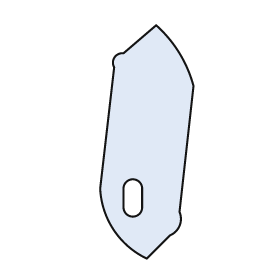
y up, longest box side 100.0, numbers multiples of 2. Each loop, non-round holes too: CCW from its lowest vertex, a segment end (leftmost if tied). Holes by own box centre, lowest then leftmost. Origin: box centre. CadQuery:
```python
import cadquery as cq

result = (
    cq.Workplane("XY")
    .moveTo(0.0, -50.0)
    .lineTo(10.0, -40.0)
    .threePointArc((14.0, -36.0), (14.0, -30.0))
    .lineTo(20.0, 24.0)
    .threePointArc((14.0, 38.0), (4.0, 50.0))
    .lineTo(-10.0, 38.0)
    .threePointArc((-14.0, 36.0), (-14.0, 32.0))
    .lineTo(-20.0, -20.0)
    .threePointArc((-14.0, -38.0), (0.0, -50.0))
    .close()
    .moveTo(-10.0, -28.0)
    .threePointArc((-6.0, -32.0), (-2.0, -28.0))
    .lineTo(-2.0, -20.0)
    .threePointArc((-6.0, -16.0), (-10.0, -20.0))
    .close()
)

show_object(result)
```